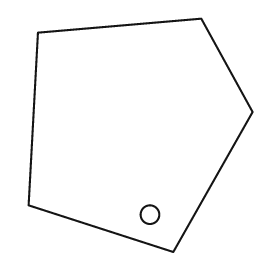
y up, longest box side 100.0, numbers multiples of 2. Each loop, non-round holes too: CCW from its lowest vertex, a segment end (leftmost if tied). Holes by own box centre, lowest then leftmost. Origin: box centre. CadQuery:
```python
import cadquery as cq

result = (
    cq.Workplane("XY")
    .moveTo(14.0, -50.0)
    .lineTo(48.0, 10.0)
    .lineTo(26.0, 50.0)
    .lineTo(-44.0, 44.0)
    .lineTo(-48.0, -30.0)
    .close()
    .moveTo(4.0, -34.0)
    .circle(4.0)
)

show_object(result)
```